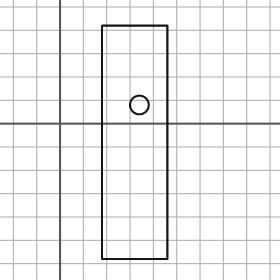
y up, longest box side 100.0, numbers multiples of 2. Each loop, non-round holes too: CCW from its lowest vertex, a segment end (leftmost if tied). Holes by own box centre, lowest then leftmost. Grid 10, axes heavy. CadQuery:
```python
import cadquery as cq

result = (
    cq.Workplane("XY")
    .moveTo(18.0, -58.0)
    .lineTo(46.0, -58.0)
    .lineTo(46.0, 42.0)
    .lineTo(18.0, 42.0)
    .close()
    .moveTo(34.0, 8.0)
    .circle(4.0)
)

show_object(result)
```